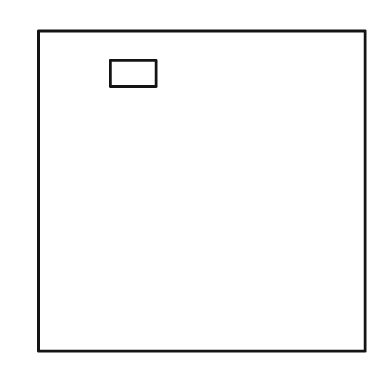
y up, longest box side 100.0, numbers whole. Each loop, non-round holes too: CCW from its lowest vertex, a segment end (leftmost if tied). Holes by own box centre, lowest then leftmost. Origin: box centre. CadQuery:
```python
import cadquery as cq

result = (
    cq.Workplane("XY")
    .moveTo(-50.0, -49.0)
    .lineTo(50.0, -49.0)
    .lineTo(50.0, 49.0)
    .lineTo(-50.0, 49.0)
    .close()
    .moveTo(-28.0, 32.0)
    .lineTo(-14.0, 32.0)
    .lineTo(-14.0, 40.0)
    .lineTo(-28.0, 40.0)
    .close()
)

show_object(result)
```